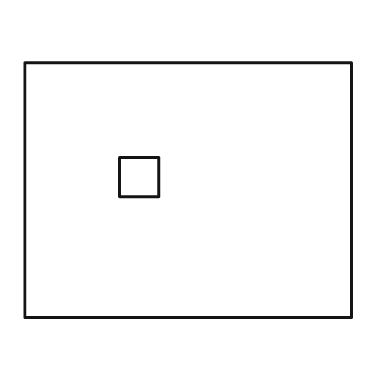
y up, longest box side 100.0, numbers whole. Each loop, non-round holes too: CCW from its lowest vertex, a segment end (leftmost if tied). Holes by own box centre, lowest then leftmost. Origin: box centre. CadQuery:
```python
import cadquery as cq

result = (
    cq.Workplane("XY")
    .moveTo(-50.0, -39.0)
    .lineTo(50.0, -39.0)
    .lineTo(50.0, 39.0)
    .lineTo(-50.0, 39.0)
    .close()
    .moveTo(-21.0, -2.0)
    .lineTo(-9.0, -2.0)
    .lineTo(-9.0, 10.0)
    .lineTo(-21.0, 10.0)
    .close()
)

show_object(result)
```